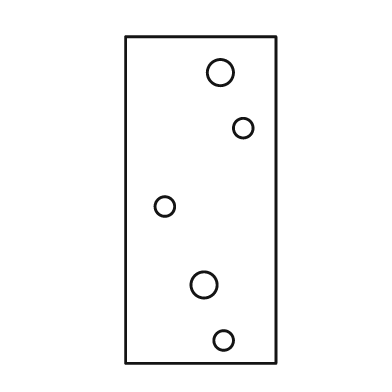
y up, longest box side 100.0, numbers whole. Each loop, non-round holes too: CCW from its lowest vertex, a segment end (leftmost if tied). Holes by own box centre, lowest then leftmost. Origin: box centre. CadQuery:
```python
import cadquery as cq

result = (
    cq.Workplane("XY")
    .moveTo(-23.0, -50.0)
    .lineTo(23.0, -50.0)
    .lineTo(23.0, 50.0)
    .lineTo(-23.0, 50.0)
    .close()
    .moveTo(7.0, -43.0)
    .circle(3.0)
    .moveTo(1.0, -26.0)
    .circle(4.0)
    .moveTo(-11.0, -2.0)
    .circle(3.0)
    .moveTo(13.0, 22.0)
    .circle(3.0)
    .moveTo(6.0, 39.0)
    .circle(4.0)
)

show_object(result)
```